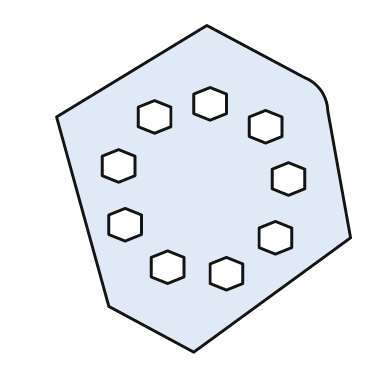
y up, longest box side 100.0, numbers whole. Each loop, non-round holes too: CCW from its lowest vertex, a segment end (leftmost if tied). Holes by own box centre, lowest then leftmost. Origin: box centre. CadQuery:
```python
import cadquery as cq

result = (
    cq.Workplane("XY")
    .moveTo(-3.0, -50.0)
    .lineTo(45.0, -15.0)
    .lineTo(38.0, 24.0)
    .threePointArc((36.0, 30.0), (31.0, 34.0))
    .lineTo(1.0, 50.0)
    .lineTo(-45.0, 22.0)
    .lineTo(-29.0, -36.0)
    .close()
    .moveTo(7.0, -31.0)
    .lineTo(12.0, -29.0)
    .lineTo(12.0, -23.0)
    .lineTo(7.0, -21.0)
    .lineTo(2.0, -23.0)
    .lineTo(2.0, -29.0)
    .close()
    .moveTo(-11.0, -29.0)
    .lineTo(-6.0, -27.0)
    .lineTo(-6.0, -21.0)
    .lineTo(-11.0, -19.0)
    .lineTo(-16.0, -21.0)
    .lineTo(-16.0, -27.0)
    .close()
    .moveTo(22.0, -20.0)
    .lineTo(27.0, -18.0)
    .lineTo(27.0, -12.0)
    .lineTo(22.0, -10.0)
    .lineTo(17.0, -12.0)
    .lineTo(17.0, -18.0)
    .close()
    .moveTo(-24.0, -16.0)
    .lineTo(-19.0, -14.0)
    .lineTo(-19.0, -8.0)
    .lineTo(-24.0, -6.0)
    .lineTo(-29.0, -8.0)
    .lineTo(-29.0, -14.0)
    .close()
    .moveTo(26.0, -2.0)
    .lineTo(31.0, 0.0)
    .lineTo(31.0, 6.0)
    .lineTo(26.0, 8.0)
    .lineTo(21.0, 6.0)
    .lineTo(21.0, 0.0)
    .close()
    .moveTo(-26.0, 2.0)
    .lineTo(-21.0, 4.0)
    .lineTo(-21.0, 10.0)
    .lineTo(-26.0, 12.0)
    .lineTo(-31.0, 10.0)
    .lineTo(-31.0, 4.0)
    .close()
    .moveTo(19.0, 14.0)
    .lineTo(24.0, 16.0)
    .lineTo(24.0, 22.0)
    .lineTo(19.0, 24.0)
    .lineTo(14.0, 22.0)
    .lineTo(14.0, 16.0)
    .close()
    .moveTo(-15.0, 17.0)
    .lineTo(-10.0, 19.0)
    .lineTo(-10.0, 25.0)
    .lineTo(-15.0, 27.0)
    .lineTo(-20.0, 25.0)
    .lineTo(-20.0, 19.0)
    .close()
    .moveTo(2.0, 21.0)
    .lineTo(7.0, 23.0)
    .lineTo(7.0, 29.0)
    .lineTo(2.0, 31.0)
    .lineTo(-3.0, 29.0)
    .lineTo(-3.0, 23.0)
    .close()
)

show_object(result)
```